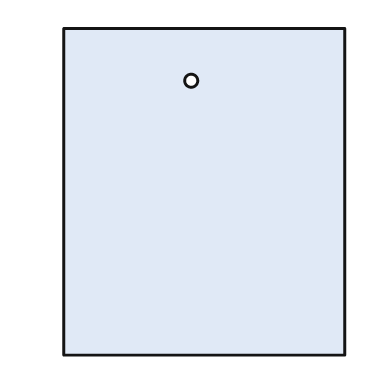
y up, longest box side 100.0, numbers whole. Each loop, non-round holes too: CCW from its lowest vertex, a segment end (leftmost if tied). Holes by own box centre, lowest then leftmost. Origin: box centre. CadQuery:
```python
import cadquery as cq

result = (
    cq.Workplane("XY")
    .moveTo(-43.0, -50.0)
    .lineTo(43.0, -50.0)
    .lineTo(43.0, 50.0)
    .lineTo(-43.0, 50.0)
    .close()
    .moveTo(-4.0, 34.0)
    .circle(2.0)
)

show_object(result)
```